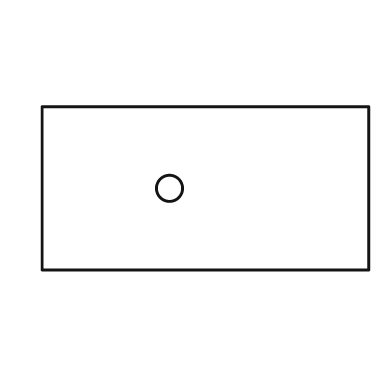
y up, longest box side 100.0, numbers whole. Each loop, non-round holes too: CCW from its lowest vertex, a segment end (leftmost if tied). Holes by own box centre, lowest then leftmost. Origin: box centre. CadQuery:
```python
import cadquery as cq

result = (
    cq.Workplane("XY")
    .moveTo(-50.0, -25.0)
    .lineTo(50.0, -25.0)
    .lineTo(50.0, 25.0)
    .lineTo(-50.0, 25.0)
    .close()
    .moveTo(-11.0, 0.0)
    .circle(4.0)
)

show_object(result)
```